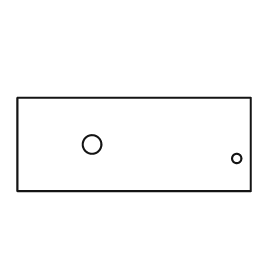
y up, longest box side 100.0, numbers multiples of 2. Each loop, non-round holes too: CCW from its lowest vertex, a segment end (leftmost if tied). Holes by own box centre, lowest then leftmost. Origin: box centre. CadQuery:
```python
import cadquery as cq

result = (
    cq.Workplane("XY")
    .moveTo(-50.0, -20.0)
    .lineTo(50.0, -20.0)
    .lineTo(50.0, 20.0)
    .lineTo(-50.0, 20.0)
    .close()
    .moveTo(44.0, -6.0)
    .circle(2.0)
    .moveTo(-18.0, 0.0)
    .circle(4.0)
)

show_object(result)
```